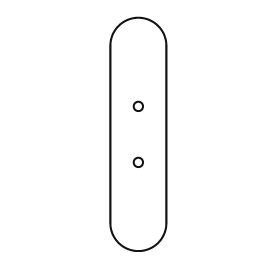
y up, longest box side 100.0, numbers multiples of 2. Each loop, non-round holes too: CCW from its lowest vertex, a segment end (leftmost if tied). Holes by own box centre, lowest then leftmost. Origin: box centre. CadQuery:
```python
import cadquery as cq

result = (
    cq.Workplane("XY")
    .moveTo(-12.0, -38.0)
    .threePointArc((0.0, -50.0), (12.0, -38.0))
    .lineTo(12.0, 38.0)
    .threePointArc((0.0, 50.0), (-12.0, 38.0))
    .close()
    .moveTo(0.0, -12.0)
    .circle(2.0)
    .moveTo(0.0, 12.0)
    .circle(2.0)
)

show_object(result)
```